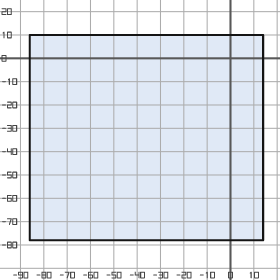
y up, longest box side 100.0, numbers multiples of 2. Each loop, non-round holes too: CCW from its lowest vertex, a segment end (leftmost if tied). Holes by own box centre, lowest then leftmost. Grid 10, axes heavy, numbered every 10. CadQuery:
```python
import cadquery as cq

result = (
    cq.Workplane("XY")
    .moveTo(-86.0, -78.0)
    .lineTo(14.0, -78.0)
    .lineTo(14.0, 10.0)
    .lineTo(-86.0, 10.0)
    .close()
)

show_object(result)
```